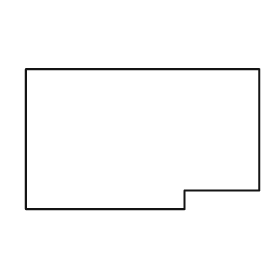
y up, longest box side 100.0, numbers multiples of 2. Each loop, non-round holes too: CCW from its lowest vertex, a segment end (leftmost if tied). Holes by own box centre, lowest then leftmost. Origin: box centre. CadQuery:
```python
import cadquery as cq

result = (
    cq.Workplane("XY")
    .moveTo(-50.0, -30.0)
    .lineTo(18.0, -30.0)
    .lineTo(18.0, -22.0)
    .lineTo(50.0, -22.0)
    .lineTo(50.0, 30.0)
    .lineTo(-50.0, 30.0)
    .close()
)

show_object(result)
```